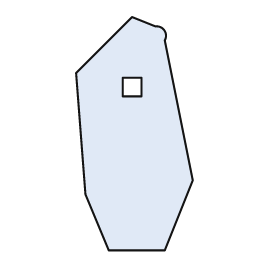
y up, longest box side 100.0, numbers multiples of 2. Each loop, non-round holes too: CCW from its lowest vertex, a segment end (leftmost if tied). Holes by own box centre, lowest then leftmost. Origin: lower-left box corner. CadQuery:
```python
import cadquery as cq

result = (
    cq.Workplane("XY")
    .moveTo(14.0, 0.0)
    .lineTo(38.0, 0.0)
    .lineTo(50.0, 30.0)
    .lineTo(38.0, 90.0)
    .threePointArc((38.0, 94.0), (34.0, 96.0))
    .lineTo(24.0, 100.0)
    .lineTo(0.0, 76.0)
    .lineTo(4.0, 24.0)
    .close()
    .moveTo(20.0, 66.0)
    .lineTo(28.0, 66.0)
    .lineTo(28.0, 74.0)
    .lineTo(20.0, 74.0)
    .close()
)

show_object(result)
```